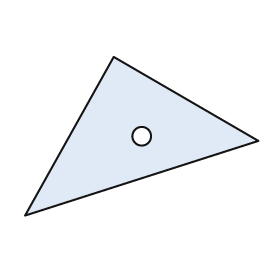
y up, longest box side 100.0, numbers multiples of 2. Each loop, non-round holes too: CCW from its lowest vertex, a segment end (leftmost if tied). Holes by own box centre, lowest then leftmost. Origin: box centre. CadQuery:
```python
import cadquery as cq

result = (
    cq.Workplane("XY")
    .moveTo(-50.0, -34.0)
    .lineTo(50.0, -2.0)
    .lineTo(-12.0, 34.0)
    .close()
    .moveTo(0.0, 0.0)
    .circle(4.0)
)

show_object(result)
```